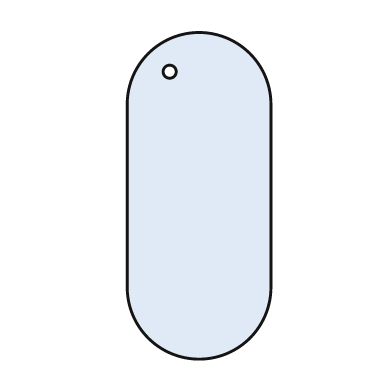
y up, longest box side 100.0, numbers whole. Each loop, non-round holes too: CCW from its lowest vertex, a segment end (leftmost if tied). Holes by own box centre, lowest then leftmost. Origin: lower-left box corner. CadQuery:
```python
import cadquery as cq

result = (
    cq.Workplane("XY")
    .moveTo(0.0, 22.0)
    .threePointArc((22.0, 0.0), (44.0, 22.0))
    .lineTo(44.0, 78.0)
    .threePointArc((22.0, 100.0), (0.0, 78.0))
    .close()
    .moveTo(13.0, 88.0)
    .circle(2.0)
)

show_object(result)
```